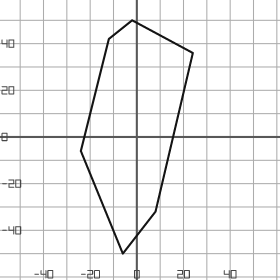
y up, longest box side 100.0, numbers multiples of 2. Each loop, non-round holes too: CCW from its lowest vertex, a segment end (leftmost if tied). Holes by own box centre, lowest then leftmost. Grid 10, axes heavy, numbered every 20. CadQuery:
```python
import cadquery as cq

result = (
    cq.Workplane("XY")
    .moveTo(-6.0, -50.0)
    .lineTo(8.0, -32.0)
    .lineTo(24.0, 36.0)
    .lineTo(-2.0, 50.0)
    .lineTo(-12.0, 42.0)
    .lineTo(-24.0, -6.0)
    .close()
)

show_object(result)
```